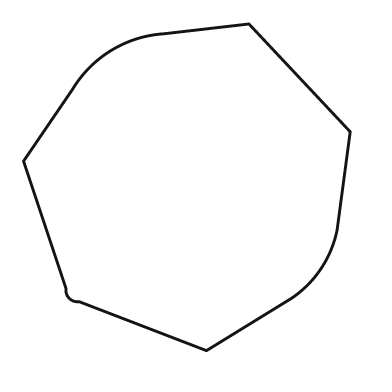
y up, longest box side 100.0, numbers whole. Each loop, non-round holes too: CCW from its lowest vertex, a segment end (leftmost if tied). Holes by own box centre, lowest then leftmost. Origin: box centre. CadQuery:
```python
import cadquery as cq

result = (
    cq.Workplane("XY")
    .moveTo(6.0, -50.0)
    .lineTo(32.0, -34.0)
    .threePointArc((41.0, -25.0), (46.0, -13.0))
    .lineTo(50.0, 17.0)
    .lineTo(19.0, 50.0)
    .lineTo(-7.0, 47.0)
    .threePointArc((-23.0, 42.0), (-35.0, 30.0))
    .lineTo(-50.0, 8.0)
    .lineTo(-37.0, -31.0)
    .threePointArc((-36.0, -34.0), (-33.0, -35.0))
    .close()
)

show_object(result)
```